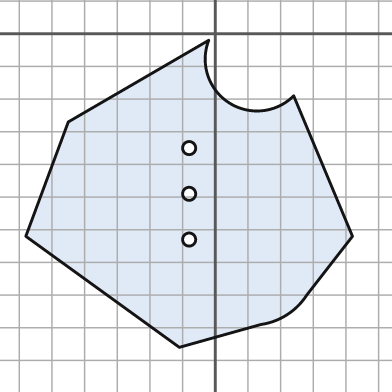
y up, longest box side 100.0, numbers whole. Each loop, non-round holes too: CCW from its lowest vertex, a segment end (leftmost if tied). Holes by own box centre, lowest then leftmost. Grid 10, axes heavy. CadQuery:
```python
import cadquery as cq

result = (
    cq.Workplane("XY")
    .moveTo(-11.0, -96.0)
    .lineTo(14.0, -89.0)
    .threePointArc((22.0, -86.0), (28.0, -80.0))
    .lineTo(42.0, -62.0)
    .lineTo(24.0, -19.0)
    .threePointArc((4.0, -21.0), (-2.0, -2.0))
    .lineTo(-45.0, -27.0)
    .lineTo(-58.0, -62.0)
    .close()
    .moveTo(-8.0, -63.0)
    .circle(2.0)
    .moveTo(-8.0, -49.0)
    .circle(2.0)
    .moveTo(-8.0, -35.0)
    .circle(2.0)
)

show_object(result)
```